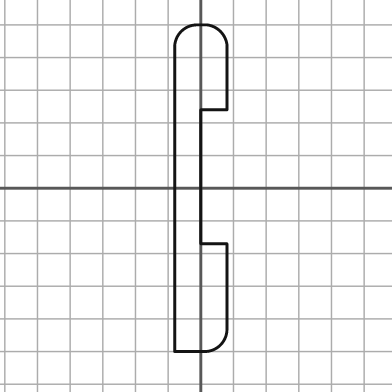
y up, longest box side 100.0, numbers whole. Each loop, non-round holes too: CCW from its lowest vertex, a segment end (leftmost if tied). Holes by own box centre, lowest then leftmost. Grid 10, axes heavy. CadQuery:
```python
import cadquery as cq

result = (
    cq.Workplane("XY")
    .moveTo(-8.0, -50.0)
    .lineTo(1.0, -50.0)
    .threePointArc((6.0, -48.0), (8.0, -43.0))
    .lineTo(8.0, -17.0)
    .lineTo(0.0, -17.0)
    .lineTo(0.0, 24.0)
    .lineTo(8.0, 24.0)
    .lineTo(8.0, 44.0)
    .threePointArc((6.0, 48.0), (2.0, 50.0))
    .lineTo(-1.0, 50.0)
    .threePointArc((-6.0, 48.0), (-8.0, 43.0))
    .close()
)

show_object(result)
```